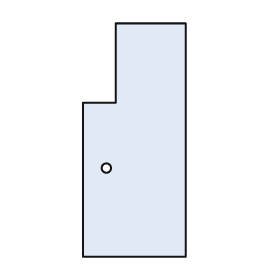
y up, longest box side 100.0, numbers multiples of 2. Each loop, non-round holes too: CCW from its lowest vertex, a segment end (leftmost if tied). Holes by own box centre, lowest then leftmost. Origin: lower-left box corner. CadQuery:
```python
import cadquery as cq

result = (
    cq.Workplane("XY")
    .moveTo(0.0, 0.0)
    .lineTo(44.0, 0.0)
    .lineTo(44.0, 100.0)
    .lineTo(14.0, 100.0)
    .lineTo(14.0, 66.0)
    .lineTo(0.0, 66.0)
    .close()
    .moveTo(10.0, 38.0)
    .circle(2.0)
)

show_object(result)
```